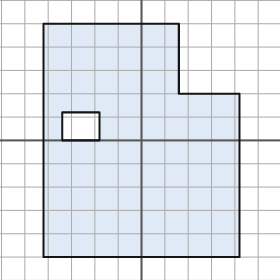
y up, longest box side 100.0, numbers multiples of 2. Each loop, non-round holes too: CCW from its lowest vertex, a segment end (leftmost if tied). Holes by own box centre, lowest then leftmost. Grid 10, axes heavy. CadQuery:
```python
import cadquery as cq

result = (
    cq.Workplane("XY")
    .moveTo(-42.0, -50.0)
    .lineTo(42.0, -50.0)
    .lineTo(42.0, 20.0)
    .lineTo(16.0, 20.0)
    .lineTo(16.0, 50.0)
    .lineTo(-42.0, 50.0)
    .close()
    .moveTo(-34.0, 0.0)
    .lineTo(-18.0, 0.0)
    .lineTo(-18.0, 12.0)
    .lineTo(-34.0, 12.0)
    .close()
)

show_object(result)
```